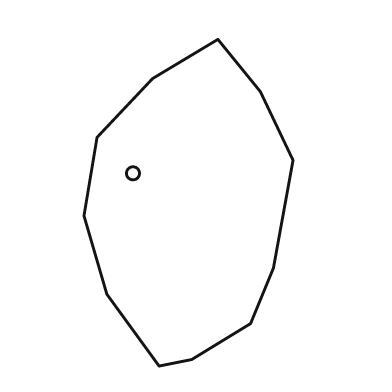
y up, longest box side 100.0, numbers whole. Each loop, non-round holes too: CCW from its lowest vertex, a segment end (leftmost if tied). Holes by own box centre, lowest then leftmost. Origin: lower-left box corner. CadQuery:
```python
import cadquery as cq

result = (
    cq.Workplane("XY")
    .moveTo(23.0, 0.0)
    .lineTo(33.0, 2.0)
    .lineTo(51.0, 13.0)
    .lineTo(58.0, 30.0)
    .lineTo(64.0, 63.0)
    .lineTo(54.0, 84.0)
    .lineTo(41.0, 100.0)
    .lineTo(21.0, 88.0)
    .lineTo(4.0, 70.0)
    .lineTo(0.0, 46.0)
    .lineTo(7.0, 22.0)
    .close()
    .moveTo(15.0, 59.0)
    .circle(2.0)
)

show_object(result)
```